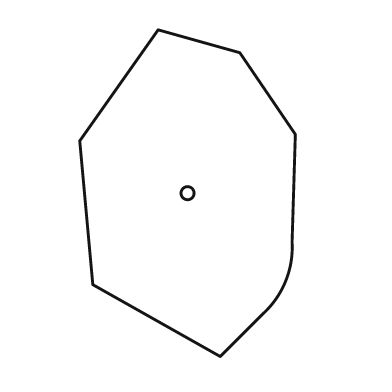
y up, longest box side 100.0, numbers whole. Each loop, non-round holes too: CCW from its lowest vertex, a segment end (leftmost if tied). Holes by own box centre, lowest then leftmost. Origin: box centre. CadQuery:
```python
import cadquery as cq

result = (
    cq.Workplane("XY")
    .moveTo(10.0, -50.0)
    .lineTo(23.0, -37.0)
    .threePointArc((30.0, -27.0), (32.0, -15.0))
    .lineTo(33.0, 18.0)
    .lineTo(16.0, 43.0)
    .lineTo(-9.0, 50.0)
    .lineTo(-33.0, 16.0)
    .lineTo(-29.0, -28.0)
    .close()
    .moveTo(0.0, 0.0)
    .circle(2.0)
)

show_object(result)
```